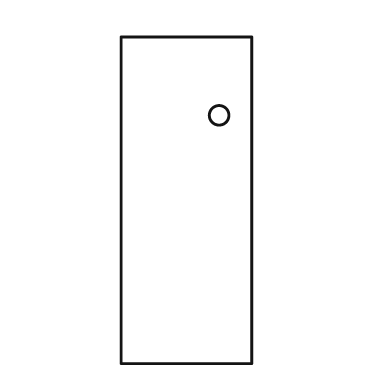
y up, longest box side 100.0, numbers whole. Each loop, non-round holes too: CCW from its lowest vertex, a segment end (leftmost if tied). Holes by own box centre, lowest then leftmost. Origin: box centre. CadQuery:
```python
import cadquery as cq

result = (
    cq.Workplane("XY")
    .moveTo(-20.0, -50.0)
    .lineTo(20.0, -50.0)
    .lineTo(20.0, 50.0)
    .lineTo(-20.0, 50.0)
    .close()
    .moveTo(10.0, 26.0)
    .circle(3.0)
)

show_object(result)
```